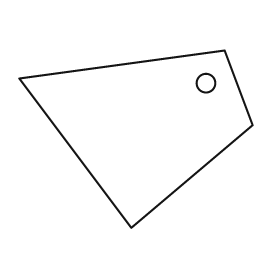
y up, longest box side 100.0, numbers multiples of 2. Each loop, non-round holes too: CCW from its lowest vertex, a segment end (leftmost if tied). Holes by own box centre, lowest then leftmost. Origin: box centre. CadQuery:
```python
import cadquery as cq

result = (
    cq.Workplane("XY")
    .moveTo(-2.0, -38.0)
    .lineTo(50.0, 6.0)
    .lineTo(38.0, 38.0)
    .lineTo(-50.0, 26.0)
    .close()
    .moveTo(30.0, 24.0)
    .circle(4.0)
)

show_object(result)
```